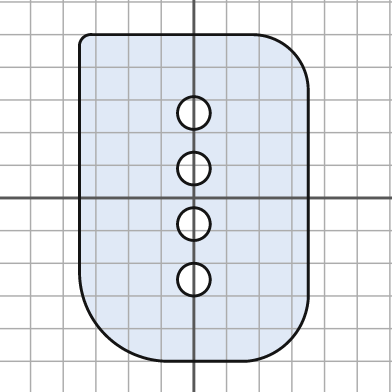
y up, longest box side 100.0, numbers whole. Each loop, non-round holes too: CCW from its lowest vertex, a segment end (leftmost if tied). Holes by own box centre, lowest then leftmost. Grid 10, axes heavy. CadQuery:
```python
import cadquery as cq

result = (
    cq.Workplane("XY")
    .moveTo(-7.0, -50.0)
    .lineTo(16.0, -50.0)
    .threePointArc((29.0, -44.0), (35.0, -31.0))
    .lineTo(35.0, 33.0)
    .threePointArc((30.0, 45.0), (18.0, 50.0))
    .lineTo(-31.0, 50.0)
    .threePointArc((-34.0, 49.0), (-35.0, 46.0))
    .lineTo(-35.0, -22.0)
    .threePointArc((-27.0, -42.0), (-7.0, -50.0))
    .close()
    .moveTo(0.0, -25.0)
    .circle(5.0)
    .moveTo(0.0, -8.0)
    .circle(5.0)
    .moveTo(0.0, 9.0)
    .circle(5.0)
    .moveTo(0.0, 26.0)
    .circle(5.0)
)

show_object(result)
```